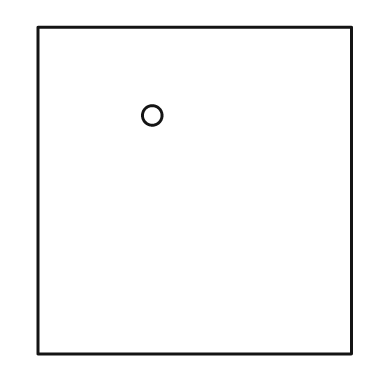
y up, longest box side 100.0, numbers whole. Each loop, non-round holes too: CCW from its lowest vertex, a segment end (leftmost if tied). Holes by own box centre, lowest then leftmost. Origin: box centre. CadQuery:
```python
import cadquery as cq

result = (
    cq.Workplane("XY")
    .moveTo(-48.0, -50.0)
    .lineTo(48.0, -50.0)
    .lineTo(48.0, 50.0)
    .lineTo(-48.0, 50.0)
    .close()
    .moveTo(-13.0, 23.0)
    .circle(3.0)
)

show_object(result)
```